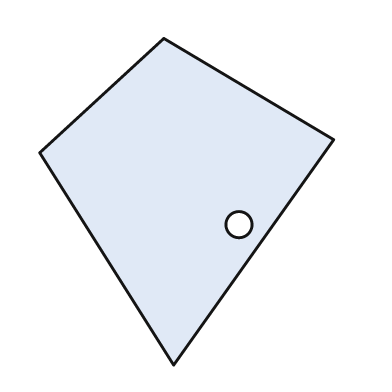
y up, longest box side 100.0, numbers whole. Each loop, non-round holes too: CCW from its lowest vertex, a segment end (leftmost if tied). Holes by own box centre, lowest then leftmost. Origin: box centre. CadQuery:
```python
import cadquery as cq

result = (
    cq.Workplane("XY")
    .moveTo(-4.0, -50.0)
    .lineTo(45.0, 19.0)
    .lineTo(-7.0, 50.0)
    .lineTo(-45.0, 15.0)
    .close()
    .moveTo(16.0, -7.0)
    .circle(4.0)
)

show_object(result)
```